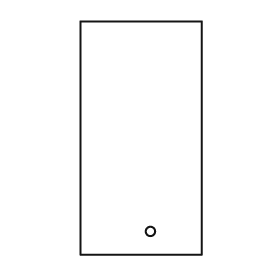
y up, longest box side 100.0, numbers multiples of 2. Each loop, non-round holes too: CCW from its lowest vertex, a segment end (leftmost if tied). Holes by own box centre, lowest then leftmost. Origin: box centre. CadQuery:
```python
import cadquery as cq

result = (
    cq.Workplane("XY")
    .moveTo(-26.0, -50.0)
    .lineTo(26.0, -50.0)
    .lineTo(26.0, 50.0)
    .lineTo(-26.0, 50.0)
    .close()
    .moveTo(4.0, -40.0)
    .circle(2.0)
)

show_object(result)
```